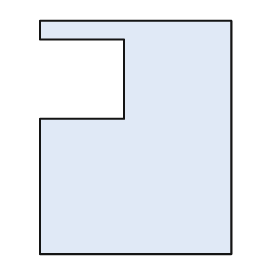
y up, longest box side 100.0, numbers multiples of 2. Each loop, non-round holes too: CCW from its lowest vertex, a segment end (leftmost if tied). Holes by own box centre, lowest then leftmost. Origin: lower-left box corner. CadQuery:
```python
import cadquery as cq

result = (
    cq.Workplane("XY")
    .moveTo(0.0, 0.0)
    .lineTo(82.0, 0.0)
    .lineTo(82.0, 100.0)
    .lineTo(0.0, 100.0)
    .lineTo(0.0, 92.0)
    .lineTo(36.0, 92.0)
    .lineTo(36.0, 58.0)
    .lineTo(0.0, 58.0)
    .close()
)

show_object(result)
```